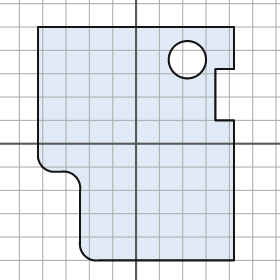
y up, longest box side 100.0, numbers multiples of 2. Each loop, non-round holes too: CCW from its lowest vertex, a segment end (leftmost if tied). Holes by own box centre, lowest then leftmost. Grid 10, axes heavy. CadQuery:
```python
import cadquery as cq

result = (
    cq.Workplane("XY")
    .moveTo(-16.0, -50.0)
    .lineTo(42.0, -50.0)
    .lineTo(42.0, 10.0)
    .lineTo(34.0, 10.0)
    .lineTo(34.0, 32.0)
    .lineTo(42.0, 32.0)
    .lineTo(42.0, 50.0)
    .lineTo(-42.0, 50.0)
    .lineTo(-42.0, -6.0)
    .threePointArc((-40.0, -10.0), (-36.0, -12.0))
    .lineTo(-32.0, -12.0)
    .threePointArc((-26.0, -14.0), (-24.0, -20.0))
    .lineTo(-24.0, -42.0)
    .threePointArc((-22.0, -48.0), (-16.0, -50.0))
    .close()
    .moveTo(22.0, 36.0)
    .circle(8.0)
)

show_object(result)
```